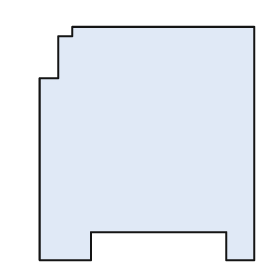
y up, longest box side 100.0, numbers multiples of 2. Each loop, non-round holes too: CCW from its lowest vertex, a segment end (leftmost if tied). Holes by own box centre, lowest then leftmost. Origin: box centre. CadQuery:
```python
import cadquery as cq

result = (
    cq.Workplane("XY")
    .moveTo(-46.0, -50.0)
    .lineTo(-24.0, -50.0)
    .lineTo(-24.0, -38.0)
    .lineTo(34.0, -38.0)
    .lineTo(34.0, -50.0)
    .lineTo(46.0, -50.0)
    .lineTo(46.0, 50.0)
    .lineTo(-32.0, 50.0)
    .lineTo(-32.0, 46.0)
    .lineTo(-38.0, 46.0)
    .lineTo(-38.0, 28.0)
    .lineTo(-46.0, 28.0)
    .close()
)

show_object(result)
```